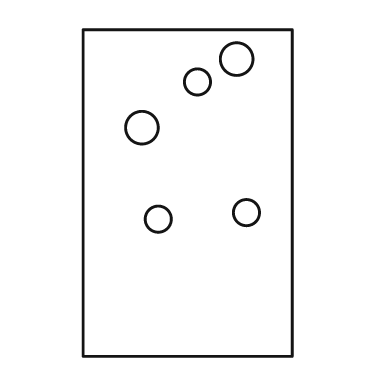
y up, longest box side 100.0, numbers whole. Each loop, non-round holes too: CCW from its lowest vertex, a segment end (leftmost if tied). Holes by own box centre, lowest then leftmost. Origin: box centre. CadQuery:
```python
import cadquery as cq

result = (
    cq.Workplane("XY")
    .moveTo(-32.0, -50.0)
    .lineTo(32.0, -50.0)
    .lineTo(32.0, 50.0)
    .lineTo(-32.0, 50.0)
    .close()
    .moveTo(-9.0, -8.0)
    .circle(4.0)
    .moveTo(18.0, -6.0)
    .circle(4.0)
    .moveTo(-14.0, 20.0)
    .circle(5.0)
    .moveTo(3.0, 34.0)
    .circle(4.0)
    .moveTo(15.0, 41.0)
    .circle(5.0)
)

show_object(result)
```